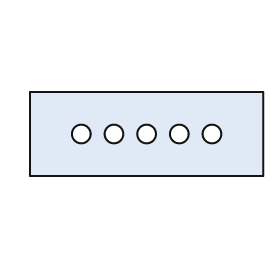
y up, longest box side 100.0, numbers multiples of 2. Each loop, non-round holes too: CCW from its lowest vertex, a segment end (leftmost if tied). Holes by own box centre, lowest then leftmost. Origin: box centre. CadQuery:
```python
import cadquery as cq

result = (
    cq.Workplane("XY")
    .moveTo(-50.0, -18.0)
    .lineTo(50.0, -18.0)
    .lineTo(50.0, 18.0)
    .lineTo(-50.0, 18.0)
    .close()
    .moveTo(-28.0, 0.0)
    .circle(4.0)
    .moveTo(-14.0, 0.0)
    .circle(4.0)
    .moveTo(0.0, 0.0)
    .circle(4.0)
    .moveTo(14.0, 0.0)
    .circle(4.0)
    .moveTo(28.0, 0.0)
    .circle(4.0)
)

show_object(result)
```